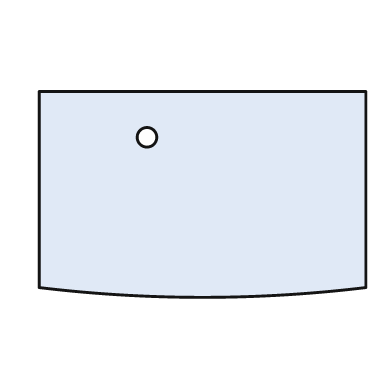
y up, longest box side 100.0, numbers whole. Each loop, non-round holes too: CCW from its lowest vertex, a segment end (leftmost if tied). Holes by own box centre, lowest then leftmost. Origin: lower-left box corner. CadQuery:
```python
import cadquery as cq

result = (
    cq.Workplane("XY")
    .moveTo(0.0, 3.0)
    .threePointArc((50.0, 0.0), (100.0, 3.0))
    .lineTo(100.0, 63.0)
    .lineTo(0.0, 63.0)
    .close()
    .moveTo(33.0, 49.0)
    .circle(3.0)
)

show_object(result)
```